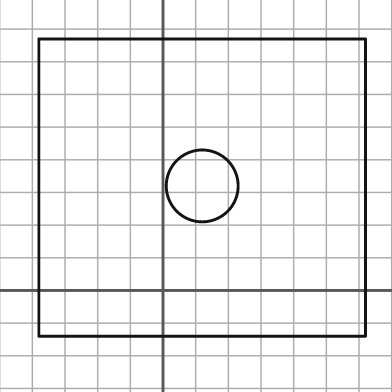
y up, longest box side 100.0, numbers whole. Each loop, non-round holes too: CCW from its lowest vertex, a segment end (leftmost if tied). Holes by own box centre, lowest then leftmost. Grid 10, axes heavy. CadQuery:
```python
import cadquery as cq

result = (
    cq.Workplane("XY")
    .moveTo(-38.0, -14.0)
    .lineTo(62.0, -14.0)
    .lineTo(62.0, 77.0)
    .lineTo(-38.0, 77.0)
    .close()
    .moveTo(12.0, 32.0)
    .circle(11.0)
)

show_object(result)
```